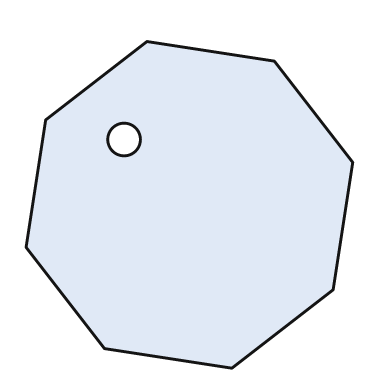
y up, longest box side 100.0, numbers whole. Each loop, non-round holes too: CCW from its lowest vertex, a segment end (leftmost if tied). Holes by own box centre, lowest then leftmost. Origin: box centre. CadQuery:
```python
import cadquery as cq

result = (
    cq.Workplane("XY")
    .moveTo(13.0, -50.0)
    .lineTo(44.0, -26.0)
    .lineTo(50.0, 13.0)
    .lineTo(26.0, 44.0)
    .lineTo(-13.0, 50.0)
    .lineTo(-44.0, 26.0)
    .lineTo(-50.0, -13.0)
    .lineTo(-26.0, -44.0)
    .close()
    .moveTo(-20.0, 20.0)
    .circle(5.0)
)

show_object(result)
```